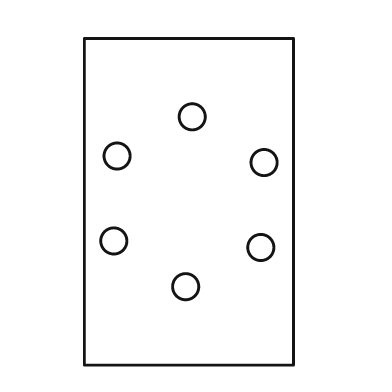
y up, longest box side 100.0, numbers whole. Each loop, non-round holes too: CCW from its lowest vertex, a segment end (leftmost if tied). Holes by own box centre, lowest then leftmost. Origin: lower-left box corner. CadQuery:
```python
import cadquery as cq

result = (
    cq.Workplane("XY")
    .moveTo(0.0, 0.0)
    .lineTo(64.0, 0.0)
    .lineTo(64.0, 100.0)
    .lineTo(0.0, 100.0)
    .close()
    .moveTo(31.0, 24.0)
    .circle(4.0)
    .moveTo(54.0, 36.0)
    .circle(4.0)
    .moveTo(9.0, 38.0)
    .circle(4.0)
    .moveTo(55.0, 62.0)
    .circle(4.0)
    .moveTo(10.0, 64.0)
    .circle(4.0)
    .moveTo(33.0, 76.0)
    .circle(4.0)
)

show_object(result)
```